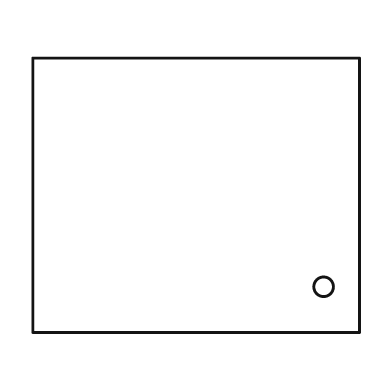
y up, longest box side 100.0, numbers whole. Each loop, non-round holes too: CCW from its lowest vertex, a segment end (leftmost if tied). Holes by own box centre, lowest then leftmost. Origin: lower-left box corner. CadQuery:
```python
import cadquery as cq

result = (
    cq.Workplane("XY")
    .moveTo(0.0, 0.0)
    .lineTo(100.0, 0.0)
    .lineTo(100.0, 84.0)
    .lineTo(0.0, 84.0)
    .close()
    .moveTo(89.0, 14.0)
    .circle(3.0)
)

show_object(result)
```